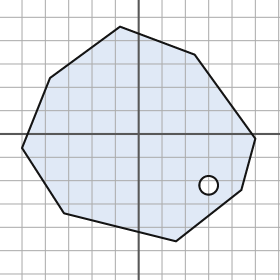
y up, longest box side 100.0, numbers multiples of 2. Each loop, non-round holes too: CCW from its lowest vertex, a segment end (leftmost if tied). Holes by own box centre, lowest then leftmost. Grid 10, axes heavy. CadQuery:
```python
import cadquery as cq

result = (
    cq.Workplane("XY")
    .moveTo(16.0, -46.0)
    .lineTo(44.0, -24.0)
    .lineTo(50.0, -2.0)
    .lineTo(24.0, 34.0)
    .lineTo(-8.0, 46.0)
    .lineTo(-38.0, 24.0)
    .lineTo(-50.0, -6.0)
    .lineTo(-32.0, -34.0)
    .close()
    .moveTo(30.0, -22.0)
    .circle(4.0)
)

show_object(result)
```